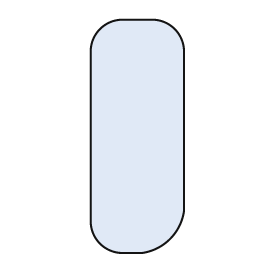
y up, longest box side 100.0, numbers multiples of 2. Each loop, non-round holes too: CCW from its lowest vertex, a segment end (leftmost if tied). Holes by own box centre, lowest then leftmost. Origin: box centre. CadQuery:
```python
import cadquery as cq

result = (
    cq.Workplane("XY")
    .moveTo(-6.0, -50.0)
    .lineTo(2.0, -50.0)
    .threePointArc((14.0, -44.0), (20.0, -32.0))
    .lineTo(20.0, 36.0)
    .threePointArc((16.0, 46.0), (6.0, 50.0))
    .lineTo(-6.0, 50.0)
    .threePointArc((-16.0, 46.0), (-20.0, 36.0))
    .lineTo(-20.0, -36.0)
    .threePointArc((-16.0, -46.0), (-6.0, -50.0))
    .close()
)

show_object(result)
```